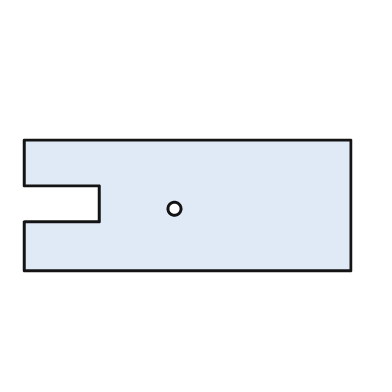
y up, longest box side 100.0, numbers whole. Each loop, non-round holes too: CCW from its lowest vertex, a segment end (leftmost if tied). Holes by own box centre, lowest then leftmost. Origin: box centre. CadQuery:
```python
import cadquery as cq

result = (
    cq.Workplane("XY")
    .moveTo(-50.0, -20.0)
    .lineTo(50.0, -20.0)
    .lineTo(50.0, 20.0)
    .lineTo(-50.0, 20.0)
    .lineTo(-50.0, 6.0)
    .lineTo(-27.0, 6.0)
    .lineTo(-27.0, -5.0)
    .lineTo(-50.0, -5.0)
    .close()
    .moveTo(-4.0, -1.0)
    .circle(2.0)
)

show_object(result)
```